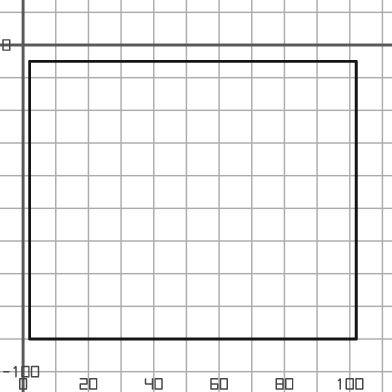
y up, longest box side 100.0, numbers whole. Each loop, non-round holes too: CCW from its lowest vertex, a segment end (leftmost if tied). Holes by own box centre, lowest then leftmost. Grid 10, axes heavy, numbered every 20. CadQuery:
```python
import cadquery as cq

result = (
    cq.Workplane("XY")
    .moveTo(2.0, -90.0)
    .lineTo(102.0, -90.0)
    .lineTo(102.0, -5.0)
    .lineTo(2.0, -5.0)
    .close()
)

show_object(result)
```